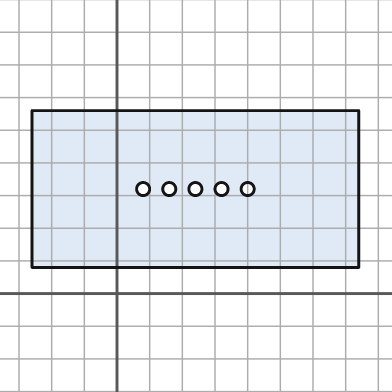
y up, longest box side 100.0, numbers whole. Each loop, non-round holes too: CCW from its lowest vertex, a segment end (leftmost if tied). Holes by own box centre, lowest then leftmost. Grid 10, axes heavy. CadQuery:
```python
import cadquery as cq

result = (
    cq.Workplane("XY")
    .moveTo(-26.0, 8.0)
    .lineTo(74.0, 8.0)
    .lineTo(74.0, 56.0)
    .lineTo(-26.0, 56.0)
    .close()
    .moveTo(8.0, 32.0)
    .circle(2.0)
    .moveTo(16.0, 32.0)
    .circle(2.0)
    .moveTo(24.0, 32.0)
    .circle(2.0)
    .moveTo(32.0, 32.0)
    .circle(2.0)
    .moveTo(40.0, 32.0)
    .circle(2.0)
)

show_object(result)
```